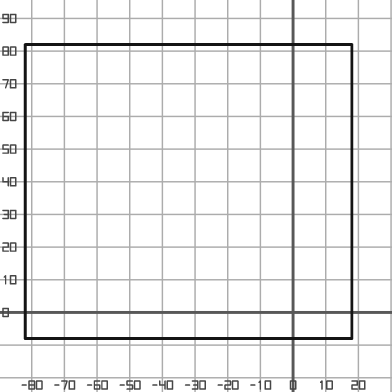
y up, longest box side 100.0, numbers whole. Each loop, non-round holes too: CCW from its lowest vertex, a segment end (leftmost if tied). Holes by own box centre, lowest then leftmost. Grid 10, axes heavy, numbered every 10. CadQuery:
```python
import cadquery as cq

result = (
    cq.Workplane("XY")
    .moveTo(-82.0, -8.0)
    .lineTo(18.0, -8.0)
    .lineTo(18.0, 82.0)
    .lineTo(-82.0, 82.0)
    .close()
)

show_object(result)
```